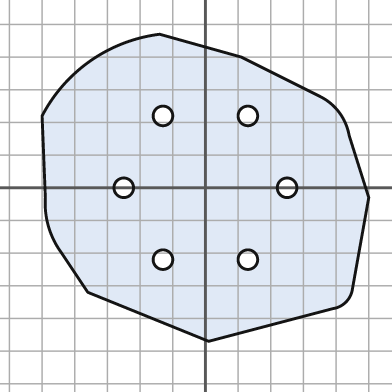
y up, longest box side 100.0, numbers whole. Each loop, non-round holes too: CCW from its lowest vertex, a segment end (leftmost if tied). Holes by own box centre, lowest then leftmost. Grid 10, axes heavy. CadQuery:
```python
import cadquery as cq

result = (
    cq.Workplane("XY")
    .moveTo(1.0, -47.0)
    .lineTo(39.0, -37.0)
    .threePointArc((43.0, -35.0), (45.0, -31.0))
    .lineTo(50.0, -3.0)
    .lineTo(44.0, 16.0)
    .threePointArc((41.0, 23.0), (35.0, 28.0))
    .lineTo(11.0, 40.0)
    .lineTo(-14.0, 47.0)
    .threePointArc((-35.0, 39.0), (-50.0, 22.0))
    .lineTo(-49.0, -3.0)
    .threePointArc((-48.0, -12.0), (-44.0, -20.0))
    .lineTo(-36.0, -32.0)
    .close()
    .moveTo(-13.0, -22.0)
    .circle(3.0)
    .moveTo(13.0, -22.0)
    .circle(3.0)
    .moveTo(-25.0, 0.0)
    .circle(3.0)
    .moveTo(25.0, 0.0)
    .circle(3.0)
    .moveTo(-13.0, 22.0)
    .circle(3.0)
    .moveTo(13.0, 22.0)
    .circle(3.0)
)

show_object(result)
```